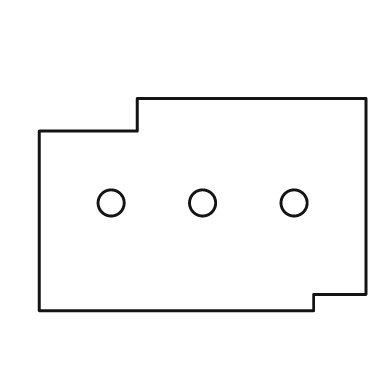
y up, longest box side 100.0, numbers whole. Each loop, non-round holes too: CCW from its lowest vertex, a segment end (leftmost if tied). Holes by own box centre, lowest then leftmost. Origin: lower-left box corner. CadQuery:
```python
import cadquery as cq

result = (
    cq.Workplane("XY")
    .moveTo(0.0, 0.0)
    .lineTo(84.0, 0.0)
    .lineTo(84.0, 5.0)
    .lineTo(100.0, 5.0)
    .lineTo(100.0, 65.0)
    .lineTo(30.0, 65.0)
    .lineTo(30.0, 55.0)
    .lineTo(0.0, 55.0)
    .close()
    .moveTo(22.0, 33.0)
    .circle(4.0)
    .moveTo(50.0, 33.0)
    .circle(4.0)
    .moveTo(78.0, 33.0)
    .circle(4.0)
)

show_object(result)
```